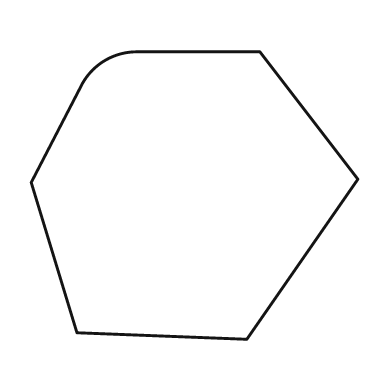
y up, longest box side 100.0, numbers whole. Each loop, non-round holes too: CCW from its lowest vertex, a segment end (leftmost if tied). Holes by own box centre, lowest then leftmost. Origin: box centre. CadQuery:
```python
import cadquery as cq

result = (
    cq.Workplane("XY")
    .moveTo(16.0, -44.0)
    .lineTo(50.0, 5.0)
    .lineTo(20.0, 44.0)
    .lineTo(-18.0, 44.0)
    .threePointArc((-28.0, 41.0), (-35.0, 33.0))
    .lineTo(-50.0, 4.0)
    .lineTo(-36.0, -42.0)
    .close()
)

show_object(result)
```